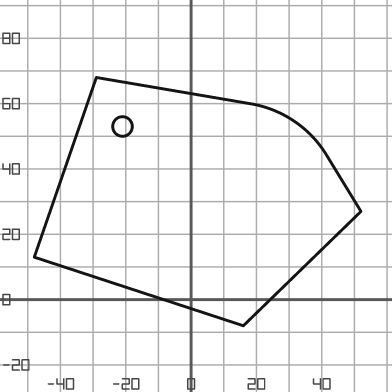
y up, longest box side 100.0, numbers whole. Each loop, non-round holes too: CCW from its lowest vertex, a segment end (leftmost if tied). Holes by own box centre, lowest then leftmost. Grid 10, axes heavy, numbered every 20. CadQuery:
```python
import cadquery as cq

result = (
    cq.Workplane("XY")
    .moveTo(16.0, -8.0)
    .lineTo(52.0, 27.0)
    .lineTo(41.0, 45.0)
    .threePointArc((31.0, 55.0), (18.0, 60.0))
    .lineTo(-29.0, 68.0)
    .lineTo(-48.0, 13.0)
    .close()
    .moveTo(-21.0, 53.0)
    .circle(3.0)
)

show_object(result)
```